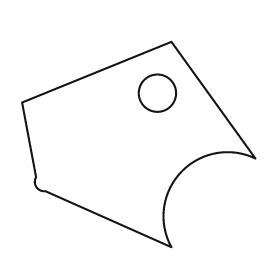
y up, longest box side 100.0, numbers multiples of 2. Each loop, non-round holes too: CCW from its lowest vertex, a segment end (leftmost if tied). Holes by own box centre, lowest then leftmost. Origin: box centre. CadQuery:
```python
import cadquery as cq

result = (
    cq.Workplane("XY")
    .moveTo(14.0, -44.0)
    .threePointArc((18.0, -12.0), (50.0, -6.0))
    .lineTo(14.0, 44.0)
    .lineTo(-50.0, 18.0)
    .lineTo(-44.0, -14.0)
    .threePointArc((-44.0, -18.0), (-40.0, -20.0))
    .close()
    .moveTo(8.0, 22.0)
    .circle(8.0)
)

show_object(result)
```